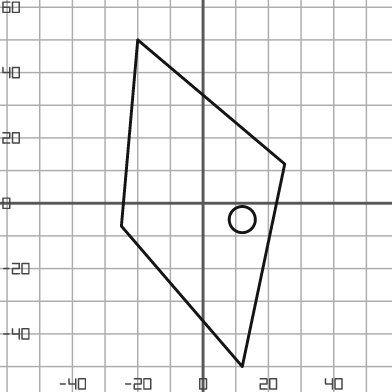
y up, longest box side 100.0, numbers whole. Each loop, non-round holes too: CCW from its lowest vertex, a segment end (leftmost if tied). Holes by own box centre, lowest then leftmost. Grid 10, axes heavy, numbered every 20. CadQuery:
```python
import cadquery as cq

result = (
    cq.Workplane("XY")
    .moveTo(12.0, -50.0)
    .lineTo(25.0, 12.0)
    .lineTo(-20.0, 50.0)
    .lineTo(-25.0, -7.0)
    .close()
    .moveTo(12.0, -5.0)
    .circle(4.0)
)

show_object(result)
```